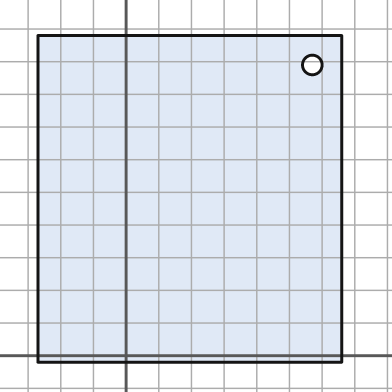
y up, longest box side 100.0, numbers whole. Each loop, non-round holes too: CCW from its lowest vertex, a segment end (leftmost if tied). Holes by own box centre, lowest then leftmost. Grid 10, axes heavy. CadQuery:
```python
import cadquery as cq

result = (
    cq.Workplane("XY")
    .moveTo(-27.0, -2.0)
    .lineTo(66.0, -2.0)
    .lineTo(66.0, 98.0)
    .lineTo(-27.0, 98.0)
    .close()
    .moveTo(57.0, 89.0)
    .circle(3.0)
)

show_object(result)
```